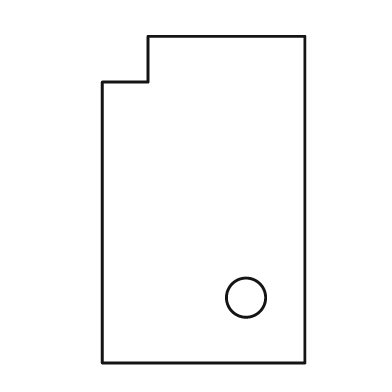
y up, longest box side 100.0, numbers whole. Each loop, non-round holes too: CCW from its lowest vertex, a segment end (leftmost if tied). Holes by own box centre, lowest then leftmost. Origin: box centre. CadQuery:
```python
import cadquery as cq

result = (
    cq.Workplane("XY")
    .moveTo(-31.0, -50.0)
    .lineTo(31.0, -50.0)
    .lineTo(31.0, 50.0)
    .lineTo(-17.0, 50.0)
    .lineTo(-17.0, 36.0)
    .lineTo(-31.0, 36.0)
    .close()
    .moveTo(13.0, -30.0)
    .circle(6.0)
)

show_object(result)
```